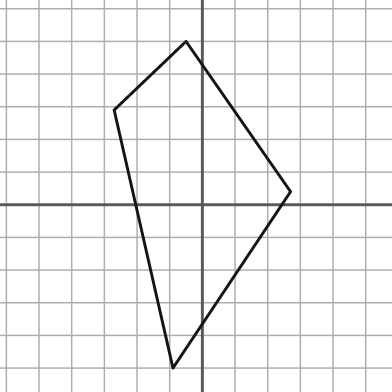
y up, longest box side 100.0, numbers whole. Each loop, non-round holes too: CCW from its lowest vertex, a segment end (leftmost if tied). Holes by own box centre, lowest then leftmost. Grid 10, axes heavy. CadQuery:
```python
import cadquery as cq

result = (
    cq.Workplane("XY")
    .moveTo(-9.0, -50.0)
    .lineTo(27.0, 4.0)
    .lineTo(-5.0, 50.0)
    .lineTo(-27.0, 29.0)
    .close()
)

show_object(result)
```